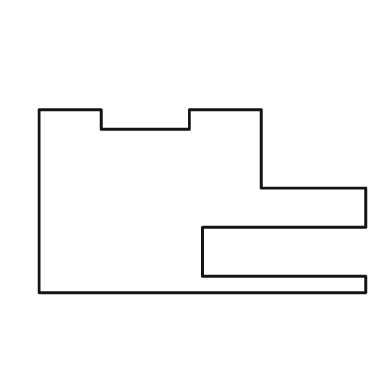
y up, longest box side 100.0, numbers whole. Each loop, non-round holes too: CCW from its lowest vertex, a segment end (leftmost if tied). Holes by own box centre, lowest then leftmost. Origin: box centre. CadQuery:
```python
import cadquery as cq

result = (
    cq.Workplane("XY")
    .moveTo(-50.0, -28.0)
    .lineTo(50.0, -28.0)
    .lineTo(50.0, -23.0)
    .lineTo(0.0, -23.0)
    .lineTo(0.0, -8.0)
    .lineTo(50.0, -8.0)
    .lineTo(50.0, 4.0)
    .lineTo(18.0, 4.0)
    .lineTo(18.0, 28.0)
    .lineTo(-4.0, 28.0)
    .lineTo(-4.0, 22.0)
    .lineTo(-31.0, 22.0)
    .lineTo(-31.0, 28.0)
    .lineTo(-50.0, 28.0)
    .close()
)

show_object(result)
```